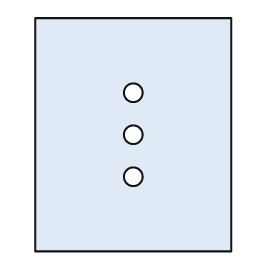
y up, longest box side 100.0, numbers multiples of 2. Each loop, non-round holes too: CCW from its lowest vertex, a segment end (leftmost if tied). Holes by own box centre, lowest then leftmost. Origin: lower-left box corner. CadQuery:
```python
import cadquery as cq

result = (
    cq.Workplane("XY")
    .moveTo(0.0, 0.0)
    .lineTo(84.0, 0.0)
    .lineTo(84.0, 100.0)
    .lineTo(0.0, 100.0)
    .close()
    .moveTo(42.0, 32.0)
    .circle(4.0)
    .moveTo(42.0, 50.0)
    .circle(4.0)
    .moveTo(42.0, 68.0)
    .circle(4.0)
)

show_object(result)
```